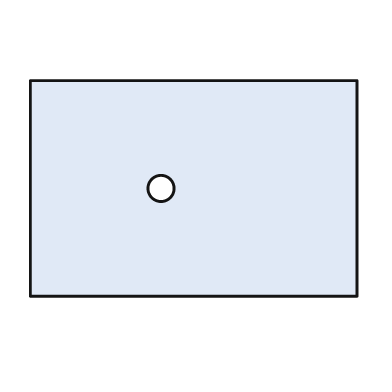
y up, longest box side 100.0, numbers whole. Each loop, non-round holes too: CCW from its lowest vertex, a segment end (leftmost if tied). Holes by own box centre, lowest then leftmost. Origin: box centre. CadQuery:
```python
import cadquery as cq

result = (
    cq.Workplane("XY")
    .moveTo(-50.0, -33.0)
    .lineTo(50.0, -33.0)
    .lineTo(50.0, 33.0)
    .lineTo(-50.0, 33.0)
    .close()
    .moveTo(-10.0, 0.0)
    .circle(4.0)
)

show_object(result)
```